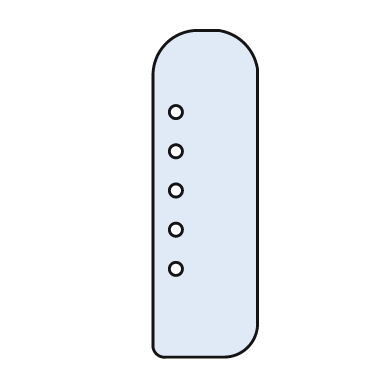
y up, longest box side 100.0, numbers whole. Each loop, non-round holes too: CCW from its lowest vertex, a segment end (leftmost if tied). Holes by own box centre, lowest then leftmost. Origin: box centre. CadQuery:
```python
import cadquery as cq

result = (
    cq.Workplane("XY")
    .moveTo(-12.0, -50.0)
    .lineTo(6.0, -50.0)
    .threePointArc((13.0, -47.0), (16.0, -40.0))
    .lineTo(16.0, 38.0)
    .threePointArc((12.0, 46.0), (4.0, 50.0))
    .lineTo(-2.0, 50.0)
    .threePointArc((-12.0, 46.0), (-16.0, 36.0))
    .lineTo(-16.0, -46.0)
    .threePointArc((-15.0, -49.0), (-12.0, -50.0))
    .close()
    .moveTo(-9.0, -23.0)
    .circle(2.0)
    .moveTo(-9.0, -11.0)
    .circle(2.0)
    .moveTo(-9.0, 1.0)
    .circle(2.0)
    .moveTo(-9.0, 13.0)
    .circle(2.0)
    .moveTo(-9.0, 25.0)
    .circle(2.0)
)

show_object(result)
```